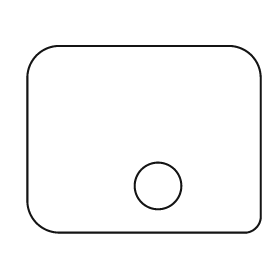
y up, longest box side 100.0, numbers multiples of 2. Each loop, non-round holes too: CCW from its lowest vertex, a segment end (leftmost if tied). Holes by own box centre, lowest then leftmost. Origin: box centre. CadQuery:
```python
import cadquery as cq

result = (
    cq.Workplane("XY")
    .moveTo(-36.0, -40.0)
    .lineTo(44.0, -40.0)
    .threePointArc((48.0, -38.0), (50.0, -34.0))
    .lineTo(50.0, 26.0)
    .threePointArc((46.0, 36.0), (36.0, 40.0))
    .lineTo(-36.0, 40.0)
    .threePointArc((-46.0, 36.0), (-50.0, 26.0))
    .lineTo(-50.0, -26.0)
    .threePointArc((-46.0, -36.0), (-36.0, -40.0))
    .close()
    .moveTo(6.0, -20.0)
    .circle(10.0)
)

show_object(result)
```